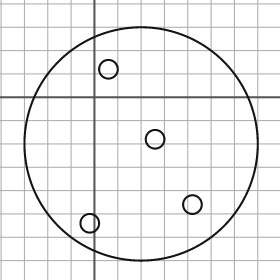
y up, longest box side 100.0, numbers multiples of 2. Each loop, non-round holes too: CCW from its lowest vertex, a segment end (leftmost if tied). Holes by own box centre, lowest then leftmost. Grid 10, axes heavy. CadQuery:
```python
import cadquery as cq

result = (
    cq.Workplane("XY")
    .moveTo(20.0, -20.0)
    .circle(50.0)
    .moveTo(-2.0, -54.0)
    .circle(4.0)
    .moveTo(42.0, -46.0)
    .circle(4.0)
    .moveTo(26.0, -18.0)
    .circle(4.0)
    .moveTo(6.0, 12.0)
    .circle(4.0)
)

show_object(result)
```